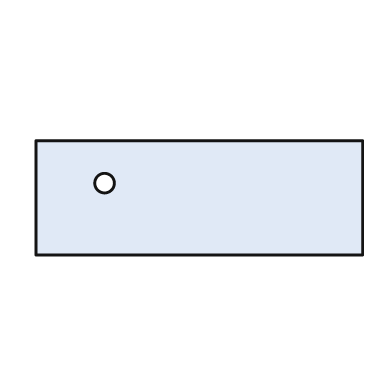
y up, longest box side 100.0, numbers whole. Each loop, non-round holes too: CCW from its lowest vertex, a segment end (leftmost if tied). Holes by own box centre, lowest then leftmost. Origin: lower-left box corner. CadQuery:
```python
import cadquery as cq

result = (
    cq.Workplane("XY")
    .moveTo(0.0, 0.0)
    .lineTo(100.0, 0.0)
    .lineTo(100.0, 35.0)
    .lineTo(0.0, 35.0)
    .close()
    .moveTo(21.0, 22.0)
    .circle(3.0)
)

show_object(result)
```